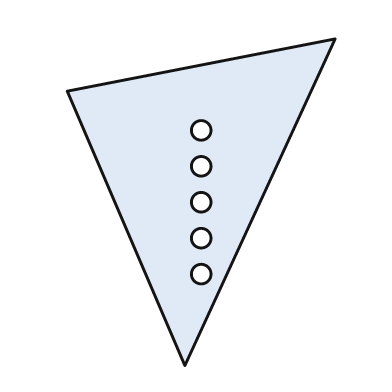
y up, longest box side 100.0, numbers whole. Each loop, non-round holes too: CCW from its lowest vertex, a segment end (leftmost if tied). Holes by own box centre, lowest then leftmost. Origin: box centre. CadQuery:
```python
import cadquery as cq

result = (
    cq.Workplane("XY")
    .moveTo(-5.0, -50.0)
    .lineTo(41.0, 50.0)
    .lineTo(-41.0, 34.0)
    .close()
    .moveTo(0.0, -22.0)
    .circle(3.0)
    .moveTo(0.0, -11.0)
    .circle(3.0)
    .moveTo(0.0, 0.0)
    .circle(3.0)
    .moveTo(0.0, 11.0)
    .circle(3.0)
    .moveTo(0.0, 22.0)
    .circle(3.0)
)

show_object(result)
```